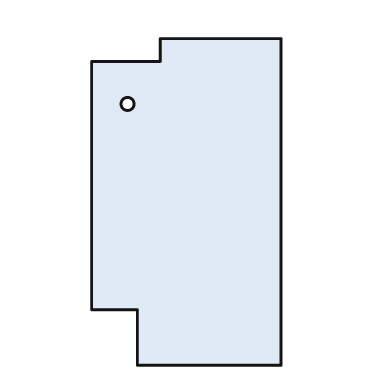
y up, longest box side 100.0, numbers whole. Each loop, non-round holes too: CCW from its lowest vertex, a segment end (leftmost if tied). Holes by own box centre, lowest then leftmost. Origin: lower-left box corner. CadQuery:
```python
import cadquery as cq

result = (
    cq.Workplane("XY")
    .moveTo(14.0, 0.0)
    .lineTo(58.0, 0.0)
    .lineTo(58.0, 100.0)
    .lineTo(21.0, 100.0)
    .lineTo(21.0, 93.0)
    .lineTo(0.0, 93.0)
    .lineTo(0.0, 17.0)
    .lineTo(14.0, 17.0)
    .close()
    .moveTo(11.0, 80.0)
    .circle(2.0)
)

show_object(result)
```